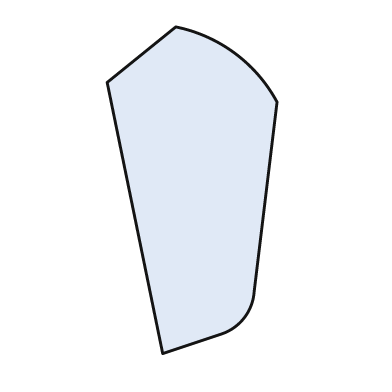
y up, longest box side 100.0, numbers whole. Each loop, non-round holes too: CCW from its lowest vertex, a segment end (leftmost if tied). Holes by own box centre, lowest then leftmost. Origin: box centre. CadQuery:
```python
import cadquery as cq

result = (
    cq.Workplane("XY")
    .moveTo(-9.0, -50.0)
    .lineTo(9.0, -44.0)
    .threePointArc((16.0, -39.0), (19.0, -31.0))
    .lineTo(26.0, 27.0)
    .threePointArc((13.0, 42.0), (-5.0, 50.0))
    .lineTo(-26.0, 33.0)
    .close()
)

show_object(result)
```